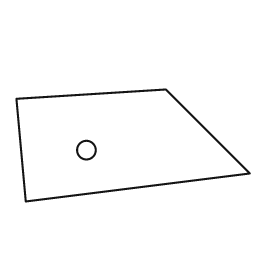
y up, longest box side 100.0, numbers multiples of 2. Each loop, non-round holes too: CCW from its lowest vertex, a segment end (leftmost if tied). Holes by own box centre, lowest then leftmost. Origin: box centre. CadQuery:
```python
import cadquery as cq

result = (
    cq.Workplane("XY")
    .moveTo(-46.0, -24.0)
    .lineTo(50.0, -12.0)
    .lineTo(14.0, 24.0)
    .lineTo(-50.0, 20.0)
    .close()
    .moveTo(-20.0, -2.0)
    .circle(4.0)
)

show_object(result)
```